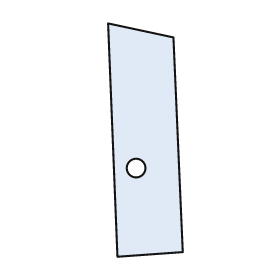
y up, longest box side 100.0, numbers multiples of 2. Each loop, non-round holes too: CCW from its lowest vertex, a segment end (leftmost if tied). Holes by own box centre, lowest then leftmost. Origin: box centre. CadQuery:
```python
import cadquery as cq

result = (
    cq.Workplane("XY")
    .moveTo(-12.0, -50.0)
    .lineTo(16.0, -48.0)
    .lineTo(12.0, 44.0)
    .lineTo(-16.0, 50.0)
    .close()
    .moveTo(-4.0, -12.0)
    .circle(4.0)
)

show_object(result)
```